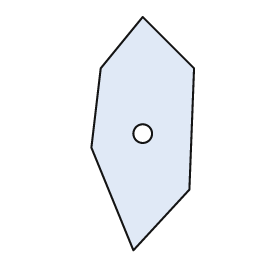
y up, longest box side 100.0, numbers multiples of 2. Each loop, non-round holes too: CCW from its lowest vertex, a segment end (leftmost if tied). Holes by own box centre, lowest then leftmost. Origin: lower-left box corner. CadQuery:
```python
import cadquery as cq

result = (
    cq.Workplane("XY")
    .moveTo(18.0, 0.0)
    .lineTo(42.0, 26.0)
    .lineTo(44.0, 78.0)
    .lineTo(22.0, 100.0)
    .lineTo(4.0, 78.0)
    .lineTo(0.0, 44.0)
    .close()
    .moveTo(22.0, 50.0)
    .circle(4.0)
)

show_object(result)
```